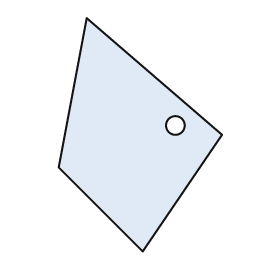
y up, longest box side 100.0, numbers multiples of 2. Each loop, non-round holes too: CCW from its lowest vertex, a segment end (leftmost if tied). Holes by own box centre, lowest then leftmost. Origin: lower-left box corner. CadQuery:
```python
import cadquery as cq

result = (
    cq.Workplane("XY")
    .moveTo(36.0, 0.0)
    .lineTo(70.0, 50.0)
    .lineTo(12.0, 100.0)
    .lineTo(0.0, 36.0)
    .close()
    .moveTo(50.0, 54.0)
    .circle(4.0)
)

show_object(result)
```